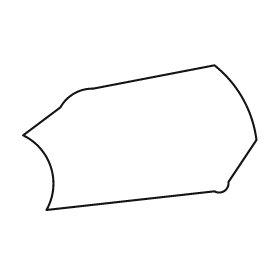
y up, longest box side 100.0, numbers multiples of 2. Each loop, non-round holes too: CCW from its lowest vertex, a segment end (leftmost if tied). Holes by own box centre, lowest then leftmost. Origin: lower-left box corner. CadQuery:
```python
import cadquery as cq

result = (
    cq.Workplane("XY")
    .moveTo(10.0, 0.0)
    .lineTo(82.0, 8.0)
    .threePointArc((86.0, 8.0), (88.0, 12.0))
    .lineTo(100.0, 30.0)
    .threePointArc((94.0, 48.0), (82.0, 62.0))
    .lineTo(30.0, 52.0)
    .threePointArc((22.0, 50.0), (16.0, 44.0))
    .lineTo(0.0, 32.0)
    .threePointArc((12.0, 18.0), (10.0, 0.0))
    .close()
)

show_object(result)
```